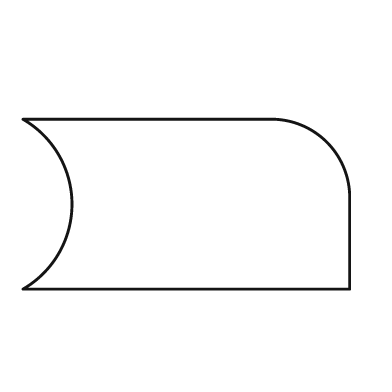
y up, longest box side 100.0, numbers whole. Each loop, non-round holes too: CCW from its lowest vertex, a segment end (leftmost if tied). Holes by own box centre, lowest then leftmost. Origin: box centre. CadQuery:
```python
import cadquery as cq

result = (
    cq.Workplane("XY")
    .moveTo(-50.0, -26.0)
    .lineTo(50.0, -26.0)
    .lineTo(50.0, 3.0)
    .threePointArc((43.0, 19.0), (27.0, 26.0))
    .lineTo(-50.0, 26.0)
    .threePointArc((-35.0, 0.0), (-50.0, -26.0))
    .close()
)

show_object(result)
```